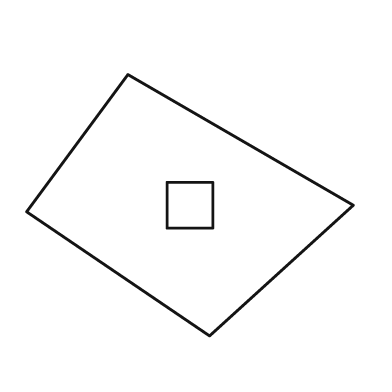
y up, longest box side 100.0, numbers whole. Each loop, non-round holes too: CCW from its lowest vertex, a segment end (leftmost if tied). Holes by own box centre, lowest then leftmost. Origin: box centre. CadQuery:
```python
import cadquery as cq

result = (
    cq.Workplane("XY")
    .moveTo(6.0, -40.0)
    .lineTo(50.0, 0.0)
    .lineTo(-19.0, 40.0)
    .lineTo(-50.0, -2.0)
    .close()
    .moveTo(-7.0, -7.0)
    .lineTo(7.0, -7.0)
    .lineTo(7.0, 7.0)
    .lineTo(-7.0, 7.0)
    .close()
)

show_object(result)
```